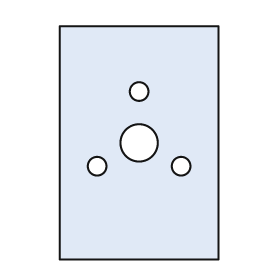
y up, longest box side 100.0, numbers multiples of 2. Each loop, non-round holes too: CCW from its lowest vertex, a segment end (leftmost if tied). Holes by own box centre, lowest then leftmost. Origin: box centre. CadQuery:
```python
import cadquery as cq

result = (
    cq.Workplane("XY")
    .moveTo(-34.0, -50.0)
    .lineTo(34.0, -50.0)
    .lineTo(34.0, 50.0)
    .lineTo(-34.0, 50.0)
    .close()
    .moveTo(-18.0, -10.0)
    .circle(4.0)
    .moveTo(18.0, -10.0)
    .circle(4.0)
    .moveTo(0.0, 0.0)
    .circle(8.0)
    .moveTo(0.0, 22.0)
    .circle(4.0)
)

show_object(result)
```